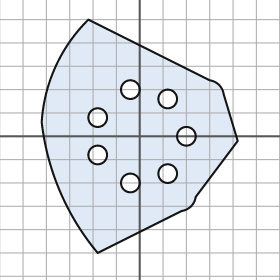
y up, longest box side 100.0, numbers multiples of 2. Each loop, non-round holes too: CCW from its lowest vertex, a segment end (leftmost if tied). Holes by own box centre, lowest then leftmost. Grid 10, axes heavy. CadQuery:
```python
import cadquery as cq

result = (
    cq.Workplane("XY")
    .moveTo(-18.0, -50.0)
    .lineTo(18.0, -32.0)
    .threePointArc((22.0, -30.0), (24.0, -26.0))
    .lineTo(42.0, -2.0)
    .lineTo(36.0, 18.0)
    .threePointArc((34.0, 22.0), (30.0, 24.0))
    .lineTo(-22.0, 50.0)
    .threePointArc((-36.0, 30.0), (-42.0, 6.0))
    .threePointArc((-34.0, -24.0), (-18.0, -50.0))
    .close()
    .moveTo(-4.0, -20.0)
    .circle(4.0)
    .moveTo(12.0, -16.0)
    .circle(4.0)
    .moveTo(-18.0, -8.0)
    .circle(4.0)
    .moveTo(20.0, 0.0)
    .circle(4.0)
    .moveTo(-18.0, 8.0)
    .circle(4.0)
    .moveTo(12.0, 16.0)
    .circle(4.0)
    .moveTo(-4.0, 20.0)
    .circle(4.0)
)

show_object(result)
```